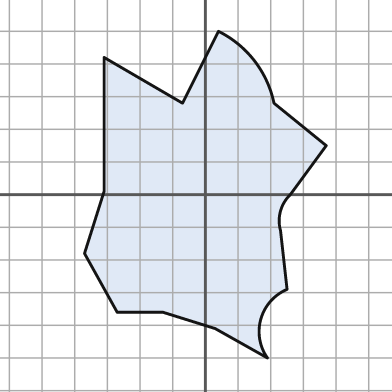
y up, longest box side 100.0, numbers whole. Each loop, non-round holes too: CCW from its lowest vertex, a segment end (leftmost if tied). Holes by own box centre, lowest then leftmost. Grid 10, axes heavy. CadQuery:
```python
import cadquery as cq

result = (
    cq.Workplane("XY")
    .moveTo(19.0, -50.0)
    .threePointArc((17.0, -38.0), (25.0, -29.0))
    .lineTo(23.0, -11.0)
    .threePointArc((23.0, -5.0), (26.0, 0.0))
    .lineTo(37.0, 15.0)
    .lineTo(21.0, 28.0)
    .threePointArc((15.0, 41.0), (4.0, 50.0))
    .lineTo(-7.0, 28.0)
    .lineTo(-31.0, 42.0)
    .lineTo(-31.0, 1.0)
    .lineTo(-37.0, -18.0)
    .lineTo(-27.0, -36.0)
    .lineTo(-13.0, -36.0)
    .lineTo(3.0, -41.0)
    .close()
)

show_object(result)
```